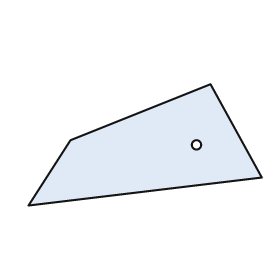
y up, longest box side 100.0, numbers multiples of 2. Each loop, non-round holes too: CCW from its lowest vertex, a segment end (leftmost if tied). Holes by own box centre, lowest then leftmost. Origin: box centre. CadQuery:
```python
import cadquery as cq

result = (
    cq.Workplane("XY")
    .moveTo(-50.0, -26.0)
    .lineTo(50.0, -14.0)
    .lineTo(28.0, 26.0)
    .lineTo(-32.0, 2.0)
    .close()
    .moveTo(22.0, 0.0)
    .circle(2.0)
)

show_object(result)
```